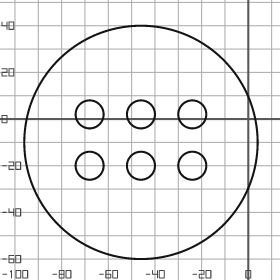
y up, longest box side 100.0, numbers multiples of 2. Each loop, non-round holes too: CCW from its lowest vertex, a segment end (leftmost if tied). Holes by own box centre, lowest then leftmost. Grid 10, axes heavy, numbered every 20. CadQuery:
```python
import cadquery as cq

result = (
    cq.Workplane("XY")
    .moveTo(-46.0, -10.0)
    .circle(50.0)
    .moveTo(-68.0, -20.0)
    .circle(6.0)
    .moveTo(-46.0, -20.0)
    .circle(6.0)
    .moveTo(-24.0, -20.0)
    .circle(6.0)
    .moveTo(-68.0, 2.0)
    .circle(6.0)
    .moveTo(-46.0, 2.0)
    .circle(6.0)
    .moveTo(-24.0, 2.0)
    .circle(6.0)
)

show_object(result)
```